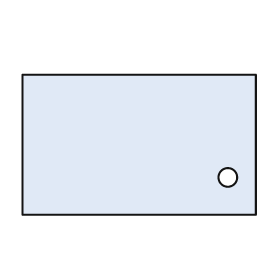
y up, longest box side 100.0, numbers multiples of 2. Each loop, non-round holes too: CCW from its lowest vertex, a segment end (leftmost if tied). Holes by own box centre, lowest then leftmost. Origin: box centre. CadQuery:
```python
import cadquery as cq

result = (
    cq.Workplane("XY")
    .moveTo(-50.0, -30.0)
    .lineTo(50.0, -30.0)
    .lineTo(50.0, 30.0)
    .lineTo(-50.0, 30.0)
    .close()
    .moveTo(38.0, -14.0)
    .circle(4.0)
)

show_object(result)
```